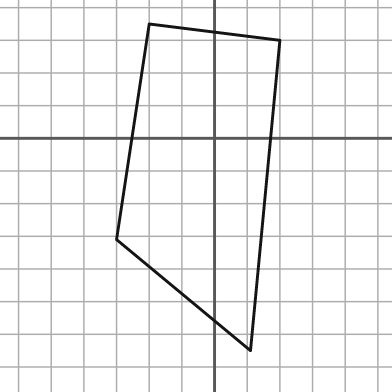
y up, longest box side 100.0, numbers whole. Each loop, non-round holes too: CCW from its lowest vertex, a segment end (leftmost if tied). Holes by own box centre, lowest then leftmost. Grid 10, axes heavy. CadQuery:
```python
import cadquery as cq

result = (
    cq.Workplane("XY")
    .moveTo(11.0, -65.0)
    .lineTo(20.0, 30.0)
    .lineTo(-20.0, 35.0)
    .lineTo(-30.0, -31.0)
    .close()
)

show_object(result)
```